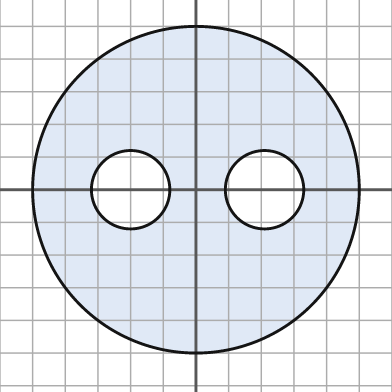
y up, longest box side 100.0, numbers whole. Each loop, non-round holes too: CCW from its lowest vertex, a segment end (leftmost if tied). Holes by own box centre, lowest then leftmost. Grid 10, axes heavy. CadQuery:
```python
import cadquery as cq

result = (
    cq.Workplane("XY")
    .moveTo(0.0, 0.0)
    .circle(50.0)
    .moveTo(-20.0, 0.0)
    .circle(12.0)
    .moveTo(21.0, 0.0)
    .circle(12.0)
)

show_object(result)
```